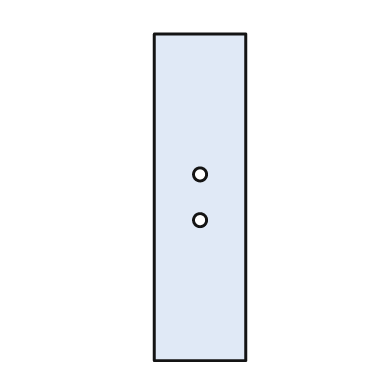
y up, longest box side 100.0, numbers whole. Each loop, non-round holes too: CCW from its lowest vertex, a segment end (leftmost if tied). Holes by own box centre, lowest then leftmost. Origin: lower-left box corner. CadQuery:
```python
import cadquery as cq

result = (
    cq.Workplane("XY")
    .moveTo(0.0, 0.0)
    .lineTo(28.0, 0.0)
    .lineTo(28.0, 100.0)
    .lineTo(0.0, 100.0)
    .close()
    .moveTo(14.0, 43.0)
    .circle(2.0)
    .moveTo(14.0, 57.0)
    .circle(2.0)
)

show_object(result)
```